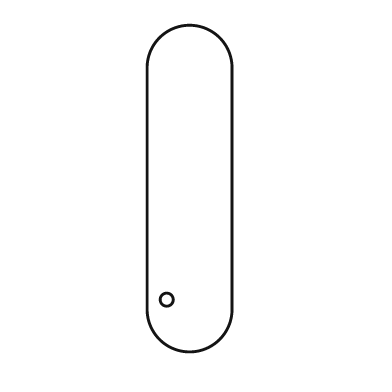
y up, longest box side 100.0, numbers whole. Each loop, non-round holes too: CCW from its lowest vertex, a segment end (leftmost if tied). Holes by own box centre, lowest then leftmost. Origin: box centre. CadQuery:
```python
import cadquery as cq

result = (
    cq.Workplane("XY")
    .moveTo(-13.0, -37.0)
    .threePointArc((0.0, -50.0), (13.0, -37.0))
    .lineTo(13.0, 37.0)
    .threePointArc((0.0, 50.0), (-13.0, 37.0))
    .close()
    .moveTo(-7.0, -34.0)
    .circle(2.0)
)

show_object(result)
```